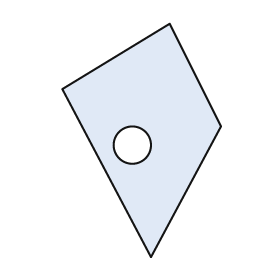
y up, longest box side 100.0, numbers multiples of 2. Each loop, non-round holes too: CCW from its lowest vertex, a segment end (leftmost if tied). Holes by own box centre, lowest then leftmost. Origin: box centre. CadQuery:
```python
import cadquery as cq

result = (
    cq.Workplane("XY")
    .moveTo(4.0, -50.0)
    .lineTo(34.0, 6.0)
    .lineTo(12.0, 50.0)
    .lineTo(-34.0, 22.0)
    .close()
    .moveTo(-4.0, -2.0)
    .circle(8.0)
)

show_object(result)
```